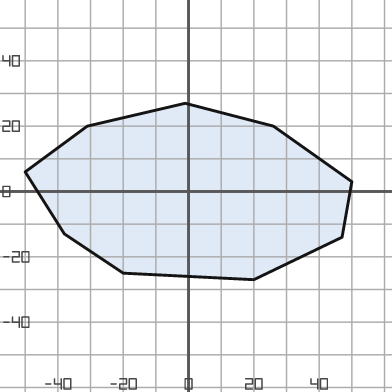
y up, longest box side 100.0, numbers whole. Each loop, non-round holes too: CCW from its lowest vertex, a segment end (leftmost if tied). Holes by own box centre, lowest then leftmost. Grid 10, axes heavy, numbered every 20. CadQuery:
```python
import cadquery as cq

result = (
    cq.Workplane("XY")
    .moveTo(20.0, -27.0)
    .lineTo(47.0, -14.0)
    .lineTo(50.0, 3.0)
    .lineTo(26.0, 20.0)
    .lineTo(-1.0, 27.0)
    .lineTo(-31.0, 20.0)
    .lineTo(-50.0, 6.0)
    .lineTo(-38.0, -13.0)
    .lineTo(-20.0, -25.0)
    .close()
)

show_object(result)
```